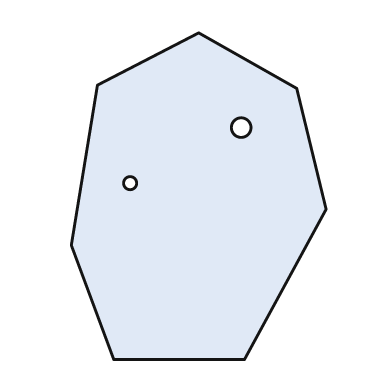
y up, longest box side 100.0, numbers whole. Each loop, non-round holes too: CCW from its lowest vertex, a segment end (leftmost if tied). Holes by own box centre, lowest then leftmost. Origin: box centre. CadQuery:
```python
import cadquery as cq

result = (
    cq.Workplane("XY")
    .moveTo(-26.0, -50.0)
    .lineTo(14.0, -50.0)
    .lineTo(39.0, -4.0)
    .lineTo(30.0, 33.0)
    .lineTo(0.0, 50.0)
    .lineTo(-31.0, 34.0)
    .lineTo(-39.0, -15.0)
    .close()
    .moveTo(-21.0, 4.0)
    .circle(2.0)
    .moveTo(13.0, 21.0)
    .circle(3.0)
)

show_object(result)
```